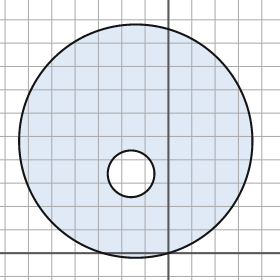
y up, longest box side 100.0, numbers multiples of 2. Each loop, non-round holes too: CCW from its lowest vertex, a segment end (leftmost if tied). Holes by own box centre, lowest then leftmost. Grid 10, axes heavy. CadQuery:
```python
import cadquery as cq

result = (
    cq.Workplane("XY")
    .moveTo(-14.0, 48.0)
    .circle(50.0)
    .moveTo(-16.0, 34.0)
    .circle(10.0)
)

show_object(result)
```